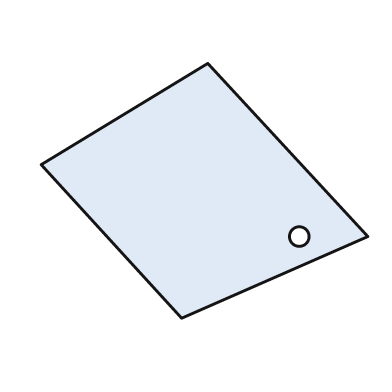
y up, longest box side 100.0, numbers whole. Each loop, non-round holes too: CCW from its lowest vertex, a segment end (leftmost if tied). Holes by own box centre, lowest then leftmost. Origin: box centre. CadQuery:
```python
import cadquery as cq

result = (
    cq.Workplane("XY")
    .moveTo(-7.0, -39.0)
    .lineTo(50.0, -14.0)
    .lineTo(1.0, 39.0)
    .lineTo(-50.0, 8.0)
    .close()
    .moveTo(29.0, -14.0)
    .circle(3.0)
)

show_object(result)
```